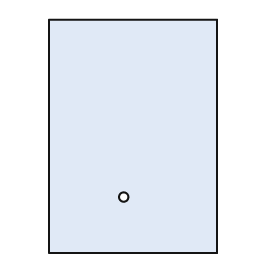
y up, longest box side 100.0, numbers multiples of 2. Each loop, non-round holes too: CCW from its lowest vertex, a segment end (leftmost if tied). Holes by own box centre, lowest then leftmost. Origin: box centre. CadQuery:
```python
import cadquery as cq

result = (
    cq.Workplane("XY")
    .moveTo(-36.0, -50.0)
    .lineTo(36.0, -50.0)
    .lineTo(36.0, 50.0)
    .lineTo(-36.0, 50.0)
    .close()
    .moveTo(-4.0, -26.0)
    .circle(2.0)
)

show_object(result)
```